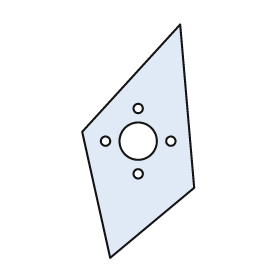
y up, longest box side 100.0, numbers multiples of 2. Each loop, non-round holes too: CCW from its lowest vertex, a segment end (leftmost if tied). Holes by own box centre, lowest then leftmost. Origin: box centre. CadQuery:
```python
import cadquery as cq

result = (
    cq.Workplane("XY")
    .moveTo(-12.0, -50.0)
    .lineTo(24.0, -20.0)
    .lineTo(18.0, 50.0)
    .lineTo(-24.0, 4.0)
    .close()
    .moveTo(0.0, -14.0)
    .circle(2.0)
    .moveTo(-14.0, 0.0)
    .circle(2.0)
    .moveTo(0.0, 0.0)
    .circle(8.0)
    .moveTo(14.0, 0.0)
    .circle(2.0)
    .moveTo(0.0, 14.0)
    .circle(2.0)
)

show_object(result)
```